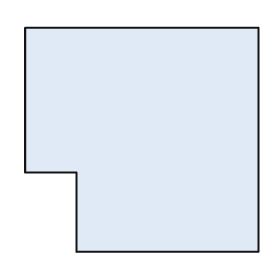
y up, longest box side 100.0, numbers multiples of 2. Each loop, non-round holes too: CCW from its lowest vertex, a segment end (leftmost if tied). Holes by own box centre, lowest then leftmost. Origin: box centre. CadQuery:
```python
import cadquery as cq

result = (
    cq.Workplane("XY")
    .moveTo(-28.0, -48.0)
    .lineTo(50.0, -48.0)
    .lineTo(50.0, 48.0)
    .lineTo(-50.0, 48.0)
    .lineTo(-50.0, -14.0)
    .lineTo(-28.0, -14.0)
    .close()
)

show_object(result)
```